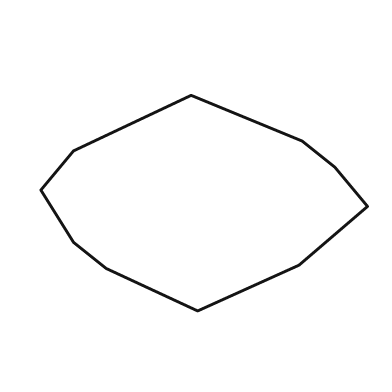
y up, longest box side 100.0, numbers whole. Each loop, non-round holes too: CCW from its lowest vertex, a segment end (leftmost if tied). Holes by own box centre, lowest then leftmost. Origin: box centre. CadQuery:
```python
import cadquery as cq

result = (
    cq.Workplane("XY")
    .moveTo(-2.0, -33.0)
    .lineTo(29.0, -19.0)
    .lineTo(50.0, -1.0)
    .lineTo(40.0, 11.0)
    .lineTo(30.0, 19.0)
    .lineTo(-4.0, 33.0)
    .lineTo(-40.0, 16.0)
    .lineTo(-50.0, 4.0)
    .lineTo(-40.0, -12.0)
    .lineTo(-30.0, -20.0)
    .close()
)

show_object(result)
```